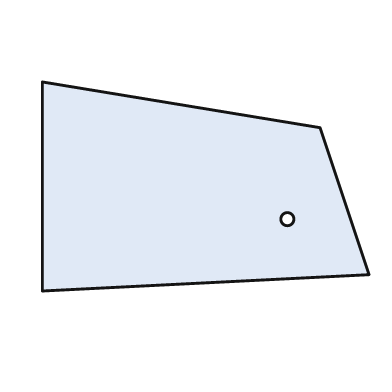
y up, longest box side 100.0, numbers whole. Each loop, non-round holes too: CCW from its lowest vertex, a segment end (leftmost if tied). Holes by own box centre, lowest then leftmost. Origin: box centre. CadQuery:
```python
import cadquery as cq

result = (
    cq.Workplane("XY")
    .moveTo(-50.0, -32.0)
    .lineTo(50.0, -27.0)
    .lineTo(35.0, 18.0)
    .lineTo(-50.0, 32.0)
    .close()
    .moveTo(25.0, -10.0)
    .circle(2.0)
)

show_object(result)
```